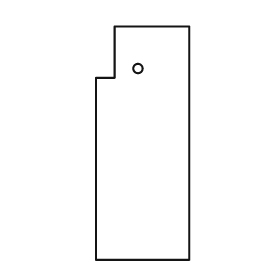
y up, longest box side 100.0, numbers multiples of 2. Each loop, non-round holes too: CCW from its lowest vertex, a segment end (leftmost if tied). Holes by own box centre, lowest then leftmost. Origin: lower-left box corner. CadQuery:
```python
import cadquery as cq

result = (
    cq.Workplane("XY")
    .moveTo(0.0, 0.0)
    .lineTo(40.0, 0.0)
    .lineTo(40.0, 100.0)
    .lineTo(8.0, 100.0)
    .lineTo(8.0, 78.0)
    .lineTo(0.0, 78.0)
    .close()
    .moveTo(18.0, 82.0)
    .circle(2.0)
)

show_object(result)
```